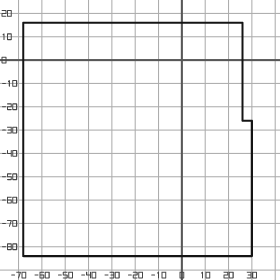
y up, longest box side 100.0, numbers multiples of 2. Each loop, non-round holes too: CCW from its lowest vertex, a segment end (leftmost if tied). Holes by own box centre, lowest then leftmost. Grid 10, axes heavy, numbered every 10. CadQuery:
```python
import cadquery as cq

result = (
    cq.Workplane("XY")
    .moveTo(-68.0, -84.0)
    .lineTo(30.0, -84.0)
    .lineTo(30.0, -26.0)
    .lineTo(26.0, -26.0)
    .lineTo(26.0, 16.0)
    .lineTo(-68.0, 16.0)
    .close()
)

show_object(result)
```